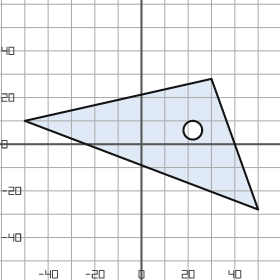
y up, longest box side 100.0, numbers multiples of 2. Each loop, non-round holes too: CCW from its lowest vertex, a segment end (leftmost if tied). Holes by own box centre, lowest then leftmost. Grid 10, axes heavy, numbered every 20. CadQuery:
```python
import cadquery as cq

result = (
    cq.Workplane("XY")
    .moveTo(50.0, -28.0)
    .lineTo(30.0, 28.0)
    .lineTo(-50.0, 10.0)
    .close()
    .moveTo(22.0, 6.0)
    .circle(4.0)
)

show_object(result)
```